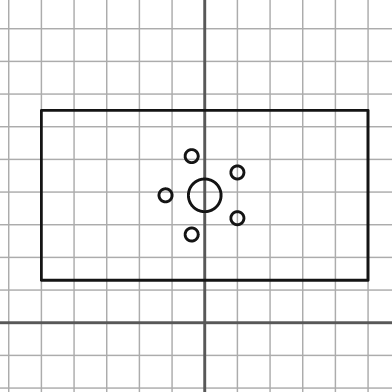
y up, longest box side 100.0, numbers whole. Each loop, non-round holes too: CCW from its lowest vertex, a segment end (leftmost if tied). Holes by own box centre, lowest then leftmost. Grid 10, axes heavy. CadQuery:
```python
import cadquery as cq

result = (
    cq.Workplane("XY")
    .moveTo(-50.0, 13.0)
    .lineTo(50.0, 13.0)
    .lineTo(50.0, 65.0)
    .lineTo(-50.0, 65.0)
    .close()
    .moveTo(-4.0, 27.0)
    .circle(2.0)
    .moveTo(10.0, 32.0)
    .circle(2.0)
    .moveTo(-12.0, 39.0)
    .circle(2.0)
    .moveTo(0.0, 39.0)
    .circle(5.0)
    .moveTo(10.0, 46.0)
    .circle(2.0)
    .moveTo(-4.0, 51.0)
    .circle(2.0)
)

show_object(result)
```